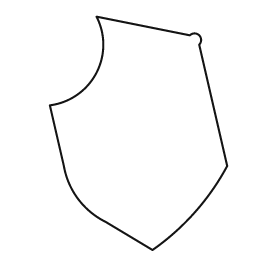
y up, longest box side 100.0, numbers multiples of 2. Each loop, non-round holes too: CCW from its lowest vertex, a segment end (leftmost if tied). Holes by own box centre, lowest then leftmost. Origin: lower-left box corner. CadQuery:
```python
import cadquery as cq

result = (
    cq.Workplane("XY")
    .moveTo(44.0, 0.0)
    .threePointArc((62.0, 16.0), (76.0, 36.0))
    .lineTo(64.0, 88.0)
    .threePointArc((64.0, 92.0), (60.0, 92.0))
    .lineTo(20.0, 100.0)
    .threePointArc((20.0, 76.0), (0.0, 62.0))
    .lineTo(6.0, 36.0)
    .threePointArc((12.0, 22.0), (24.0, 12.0))
    .close()
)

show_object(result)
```